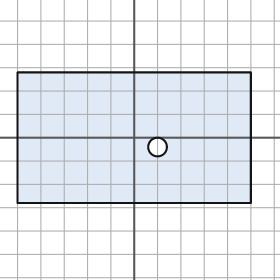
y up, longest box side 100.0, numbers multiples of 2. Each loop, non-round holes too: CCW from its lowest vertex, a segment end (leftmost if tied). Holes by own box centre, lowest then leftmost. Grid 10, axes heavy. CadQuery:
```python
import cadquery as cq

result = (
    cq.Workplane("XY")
    .moveTo(-50.0, -28.0)
    .lineTo(50.0, -28.0)
    .lineTo(50.0, 28.0)
    .lineTo(-50.0, 28.0)
    .close()
    .moveTo(10.0, -4.0)
    .circle(4.0)
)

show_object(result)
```